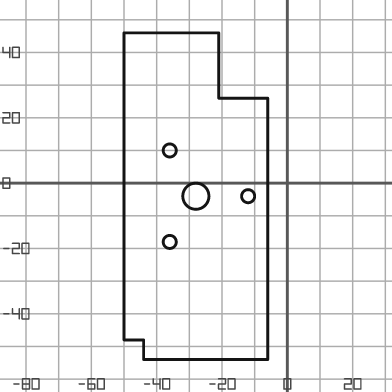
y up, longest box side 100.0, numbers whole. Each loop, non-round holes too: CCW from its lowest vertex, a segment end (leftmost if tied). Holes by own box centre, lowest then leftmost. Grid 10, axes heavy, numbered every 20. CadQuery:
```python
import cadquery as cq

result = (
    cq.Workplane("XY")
    .moveTo(-44.0, -54.0)
    .lineTo(-6.0, -54.0)
    .lineTo(-6.0, 26.0)
    .lineTo(-21.0, 26.0)
    .lineTo(-21.0, 46.0)
    .lineTo(-50.0, 46.0)
    .lineTo(-50.0, -48.0)
    .lineTo(-44.0, -48.0)
    .close()
    .moveTo(-36.0, -18.0)
    .circle(2.0)
    .moveTo(-28.0, -4.0)
    .circle(4.0)
    .moveTo(-12.0, -4.0)
    .circle(2.0)
    .moveTo(-36.0, 10.0)
    .circle(2.0)
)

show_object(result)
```